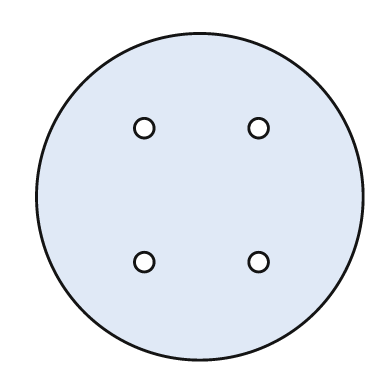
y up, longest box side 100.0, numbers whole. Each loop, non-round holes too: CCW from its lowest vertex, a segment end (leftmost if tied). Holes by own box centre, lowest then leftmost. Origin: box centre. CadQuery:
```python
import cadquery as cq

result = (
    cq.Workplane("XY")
    .moveTo(0.0, 0.0)
    .circle(50.0)
    .moveTo(-17.0, -20.0)
    .circle(3.0)
    .moveTo(18.0, -20.0)
    .circle(3.0)
    .moveTo(-17.0, 21.0)
    .circle(3.0)
    .moveTo(18.0, 21.0)
    .circle(3.0)
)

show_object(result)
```